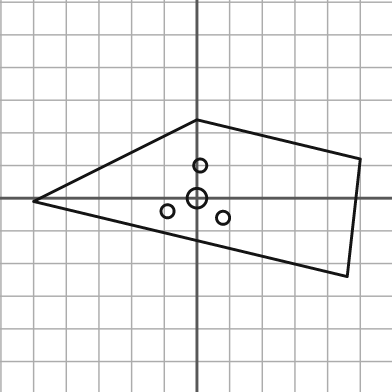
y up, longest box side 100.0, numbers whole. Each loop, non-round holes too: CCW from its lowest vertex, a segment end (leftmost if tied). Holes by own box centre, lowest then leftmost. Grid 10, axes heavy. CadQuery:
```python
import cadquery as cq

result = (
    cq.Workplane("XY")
    .moveTo(46.0, -24.0)
    .lineTo(50.0, 12.0)
    .lineTo(0.0, 24.0)
    .lineTo(-50.0, -1.0)
    .close()
    .moveTo(8.0, -6.0)
    .circle(2.0)
    .moveTo(-9.0, -4.0)
    .circle(2.0)
    .moveTo(0.0, 0.0)
    .circle(3.0)
    .moveTo(1.0, 10.0)
    .circle(2.0)
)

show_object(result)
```